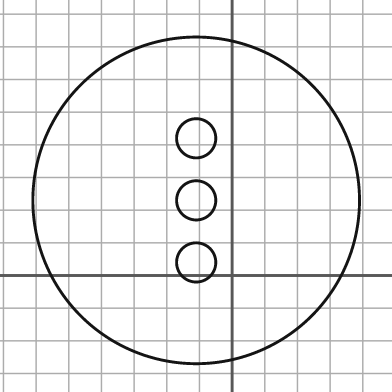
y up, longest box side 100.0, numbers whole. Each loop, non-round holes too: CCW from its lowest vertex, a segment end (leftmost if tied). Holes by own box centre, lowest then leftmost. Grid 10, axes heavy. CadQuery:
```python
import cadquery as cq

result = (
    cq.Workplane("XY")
    .moveTo(-11.0, 23.0)
    .circle(50.0)
    .moveTo(-11.0, 4.0)
    .circle(6.0)
    .moveTo(-11.0, 23.0)
    .circle(6.0)
    .moveTo(-11.0, 42.0)
    .circle(6.0)
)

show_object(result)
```